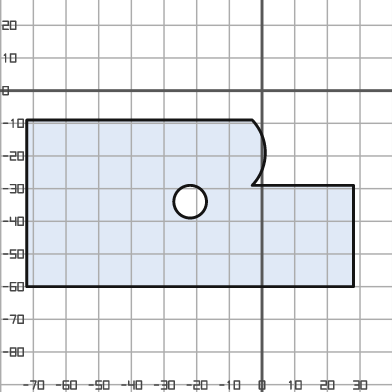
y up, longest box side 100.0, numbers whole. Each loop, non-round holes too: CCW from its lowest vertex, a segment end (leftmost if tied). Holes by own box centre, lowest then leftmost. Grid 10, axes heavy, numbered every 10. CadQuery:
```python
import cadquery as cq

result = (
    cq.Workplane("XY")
    .moveTo(-72.0, -60.0)
    .lineTo(28.0, -60.0)
    .lineTo(28.0, -29.0)
    .lineTo(-3.0, -29.0)
    .threePointArc((1.0, -19.0), (-3.0, -9.0))
    .lineTo(-72.0, -9.0)
    .close()
    .moveTo(-22.0, -34.0)
    .circle(5.0)
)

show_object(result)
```